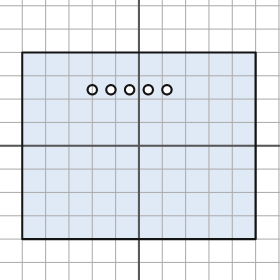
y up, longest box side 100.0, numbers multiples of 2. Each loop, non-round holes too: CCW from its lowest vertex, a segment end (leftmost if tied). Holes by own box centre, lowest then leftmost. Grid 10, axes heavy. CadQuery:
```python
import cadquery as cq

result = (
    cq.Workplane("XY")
    .moveTo(-50.0, -40.0)
    .lineTo(50.0, -40.0)
    .lineTo(50.0, 40.0)
    .lineTo(-50.0, 40.0)
    .close()
    .moveTo(-20.0, 24.0)
    .circle(2.0)
    .moveTo(-12.0, 24.0)
    .circle(2.0)
    .moveTo(-4.0, 24.0)
    .circle(2.0)
    .moveTo(4.0, 24.0)
    .circle(2.0)
    .moveTo(12.0, 24.0)
    .circle(2.0)
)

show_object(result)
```